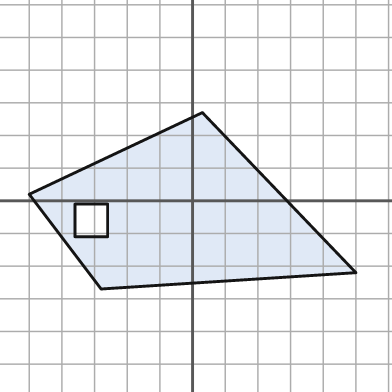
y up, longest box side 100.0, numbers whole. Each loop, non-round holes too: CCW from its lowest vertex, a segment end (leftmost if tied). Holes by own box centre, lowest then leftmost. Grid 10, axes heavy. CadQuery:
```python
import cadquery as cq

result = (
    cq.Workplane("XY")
    .moveTo(-28.0, -27.0)
    .lineTo(50.0, -22.0)
    .lineTo(3.0, 27.0)
    .lineTo(-50.0, 2.0)
    .close()
    .moveTo(-36.0, -11.0)
    .lineTo(-26.0, -11.0)
    .lineTo(-26.0, -1.0)
    .lineTo(-36.0, -1.0)
    .close()
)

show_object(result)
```